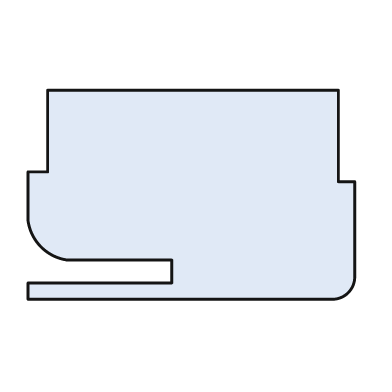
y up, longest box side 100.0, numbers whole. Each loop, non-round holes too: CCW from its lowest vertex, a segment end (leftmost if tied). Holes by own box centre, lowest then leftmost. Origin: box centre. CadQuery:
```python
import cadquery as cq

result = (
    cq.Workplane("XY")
    .moveTo(-50.0, -32.0)
    .lineTo(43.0, -32.0)
    .threePointArc((48.0, -30.0), (50.0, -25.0))
    .lineTo(50.0, 4.0)
    .lineTo(45.0, 4.0)
    .lineTo(45.0, 32.0)
    .lineTo(-44.0, 32.0)
    .lineTo(-44.0, 7.0)
    .lineTo(-50.0, 7.0)
    .lineTo(-50.0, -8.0)
    .threePointArc((-46.0, -16.0), (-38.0, -20.0))
    .lineTo(-6.0, -20.0)
    .lineTo(-6.0, -27.0)
    .lineTo(-50.0, -27.0)
    .close()
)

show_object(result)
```